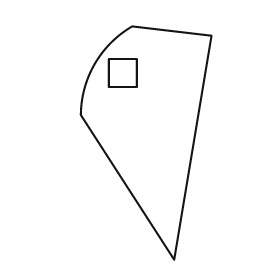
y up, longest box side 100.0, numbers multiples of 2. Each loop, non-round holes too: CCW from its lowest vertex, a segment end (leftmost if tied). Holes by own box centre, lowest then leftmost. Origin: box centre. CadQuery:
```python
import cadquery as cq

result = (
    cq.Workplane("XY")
    .moveTo(12.0, -50.0)
    .lineTo(28.0, 46.0)
    .lineTo(-6.0, 50.0)
    .threePointArc((-22.0, 34.0), (-28.0, 12.0))
    .close()
    .moveTo(-16.0, 24.0)
    .lineTo(-4.0, 24.0)
    .lineTo(-4.0, 36.0)
    .lineTo(-16.0, 36.0)
    .close()
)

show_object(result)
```